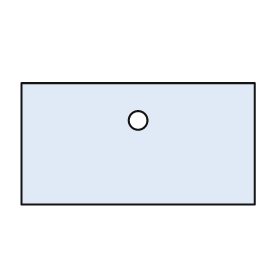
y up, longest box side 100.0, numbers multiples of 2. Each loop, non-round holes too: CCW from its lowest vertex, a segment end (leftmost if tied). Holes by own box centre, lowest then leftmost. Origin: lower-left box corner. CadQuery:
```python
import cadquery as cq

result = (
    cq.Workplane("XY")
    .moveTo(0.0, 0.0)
    .lineTo(100.0, 0.0)
    .lineTo(100.0, 52.0)
    .lineTo(0.0, 52.0)
    .close()
    .moveTo(50.0, 36.0)
    .circle(4.0)
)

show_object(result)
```